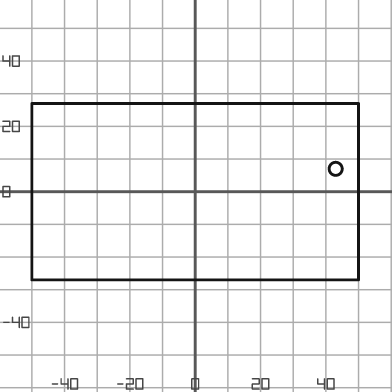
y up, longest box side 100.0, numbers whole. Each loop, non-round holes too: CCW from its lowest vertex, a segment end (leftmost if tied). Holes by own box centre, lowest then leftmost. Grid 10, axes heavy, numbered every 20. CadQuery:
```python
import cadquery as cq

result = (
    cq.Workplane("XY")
    .moveTo(-50.0, -27.0)
    .lineTo(50.0, -27.0)
    .lineTo(50.0, 27.0)
    .lineTo(-50.0, 27.0)
    .close()
    .moveTo(43.0, 7.0)
    .circle(2.0)
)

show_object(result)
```